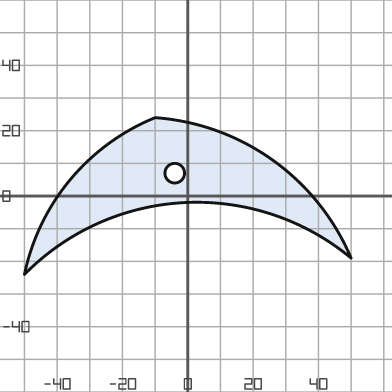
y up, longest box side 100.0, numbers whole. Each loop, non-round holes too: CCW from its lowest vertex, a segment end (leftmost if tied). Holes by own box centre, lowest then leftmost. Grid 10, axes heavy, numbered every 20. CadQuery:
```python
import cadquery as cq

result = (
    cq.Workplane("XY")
    .moveTo(-50.0, -24.0)
    .threePointArc((-1.0, -2.0), (50.0, -19.0))
    .threePointArc((26.0, 11.0), (-10.0, 24.0))
    .threePointArc((-36.0, 5.0), (-50.0, -24.0))
    .close()
    .moveTo(-4.0, 7.0)
    .circle(3.0)
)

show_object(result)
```